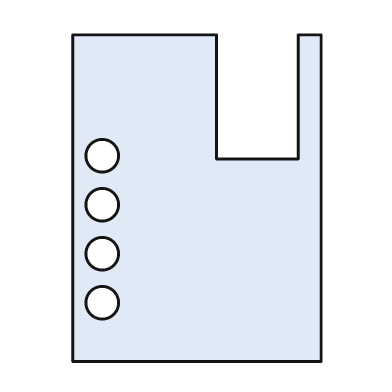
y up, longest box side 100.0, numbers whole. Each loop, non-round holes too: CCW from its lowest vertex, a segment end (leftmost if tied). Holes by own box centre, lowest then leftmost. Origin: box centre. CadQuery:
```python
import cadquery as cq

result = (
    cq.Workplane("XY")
    .moveTo(-38.0, -50.0)
    .lineTo(38.0, -50.0)
    .lineTo(38.0, 50.0)
    .lineTo(31.0, 50.0)
    .lineTo(31.0, 12.0)
    .lineTo(6.0, 12.0)
    .lineTo(6.0, 50.0)
    .lineTo(-38.0, 50.0)
    .close()
    .moveTo(-29.0, -32.0)
    .circle(5.0)
    .moveTo(-29.0, -17.0)
    .circle(5.0)
    .moveTo(-29.0, -2.0)
    .circle(5.0)
    .moveTo(-29.0, 13.0)
    .circle(5.0)
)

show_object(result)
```